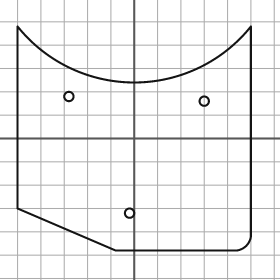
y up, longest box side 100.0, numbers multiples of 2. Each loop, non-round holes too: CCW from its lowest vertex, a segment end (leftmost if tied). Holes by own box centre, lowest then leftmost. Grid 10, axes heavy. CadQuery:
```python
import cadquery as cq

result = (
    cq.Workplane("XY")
    .moveTo(-8.0, -48.0)
    .lineTo(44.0, -48.0)
    .threePointArc((48.0, -46.0), (50.0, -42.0))
    .lineTo(50.0, 48.0)
    .threePointArc((0.0, 24.0), (-50.0, 48.0))
    .lineTo(-50.0, -30.0)
    .close()
    .moveTo(-2.0, -32.0)
    .circle(2.0)
    .moveTo(30.0, 16.0)
    .circle(2.0)
    .moveTo(-28.0, 18.0)
    .circle(2.0)
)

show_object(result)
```